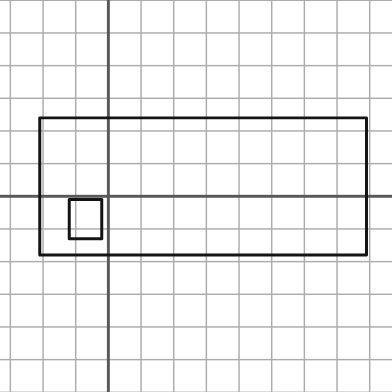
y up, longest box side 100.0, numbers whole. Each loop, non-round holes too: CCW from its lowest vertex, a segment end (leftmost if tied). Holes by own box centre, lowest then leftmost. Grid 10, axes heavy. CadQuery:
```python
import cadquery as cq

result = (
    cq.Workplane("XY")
    .moveTo(-21.0, -18.0)
    .lineTo(79.0, -18.0)
    .lineTo(79.0, 24.0)
    .lineTo(-21.0, 24.0)
    .close()
    .moveTo(-12.0, -13.0)
    .lineTo(-2.0, -13.0)
    .lineTo(-2.0, -1.0)
    .lineTo(-12.0, -1.0)
    .close()
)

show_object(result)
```